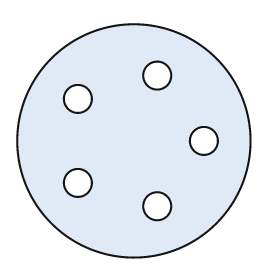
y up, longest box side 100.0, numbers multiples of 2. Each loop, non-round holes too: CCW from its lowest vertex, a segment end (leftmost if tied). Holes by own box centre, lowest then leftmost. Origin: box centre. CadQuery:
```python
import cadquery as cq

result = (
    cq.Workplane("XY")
    .moveTo(0.0, 0.0)
    .circle(50.0)
    .moveTo(10.0, -28.0)
    .circle(6.0)
    .moveTo(-24.0, -18.0)
    .circle(6.0)
    .moveTo(30.0, 0.0)
    .circle(6.0)
    .moveTo(-24.0, 18.0)
    .circle(6.0)
    .moveTo(10.0, 28.0)
    .circle(6.0)
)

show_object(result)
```